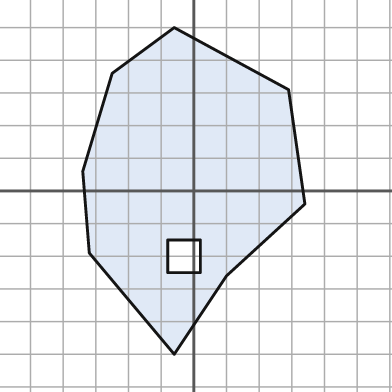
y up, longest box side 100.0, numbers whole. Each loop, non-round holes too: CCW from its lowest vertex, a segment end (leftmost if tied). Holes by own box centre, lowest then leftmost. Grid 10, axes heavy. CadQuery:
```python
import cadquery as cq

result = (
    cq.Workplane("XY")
    .moveTo(-6.0, -50.0)
    .lineTo(10.0, -26.0)
    .lineTo(34.0, -4.0)
    .lineTo(29.0, 31.0)
    .lineTo(-6.0, 50.0)
    .lineTo(-25.0, 36.0)
    .lineTo(-34.0, 6.0)
    .lineTo(-32.0, -19.0)
    .close()
    .moveTo(-8.0, -25.0)
    .lineTo(2.0, -25.0)
    .lineTo(2.0, -15.0)
    .lineTo(-8.0, -15.0)
    .close()
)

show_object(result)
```